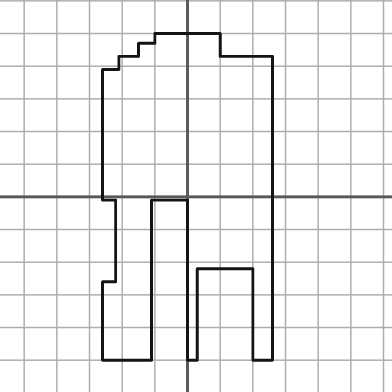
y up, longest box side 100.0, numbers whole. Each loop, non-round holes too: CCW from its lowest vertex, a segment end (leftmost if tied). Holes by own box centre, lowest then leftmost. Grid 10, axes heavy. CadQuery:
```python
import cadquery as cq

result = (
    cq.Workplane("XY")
    .moveTo(-26.0, -50.0)
    .lineTo(-11.0, -50.0)
    .lineTo(-11.0, -1.0)
    .lineTo(0.0, -1.0)
    .lineTo(0.0, -50.0)
    .lineTo(3.0, -50.0)
    .lineTo(3.0, -22.0)
    .lineTo(20.0, -22.0)
    .lineTo(20.0, -50.0)
    .lineTo(26.0, -50.0)
    .lineTo(26.0, 43.0)
    .lineTo(10.0, 43.0)
    .lineTo(10.0, 50.0)
    .lineTo(-10.0, 50.0)
    .lineTo(-10.0, 47.0)
    .lineTo(-15.0, 47.0)
    .lineTo(-15.0, 43.0)
    .lineTo(-21.0, 43.0)
    .lineTo(-21.0, 39.0)
    .lineTo(-26.0, 39.0)
    .lineTo(-26.0, -1.0)
    .lineTo(-22.0, -1.0)
    .lineTo(-22.0, -26.0)
    .lineTo(-26.0, -26.0)
    .close()
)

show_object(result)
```